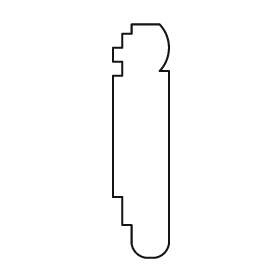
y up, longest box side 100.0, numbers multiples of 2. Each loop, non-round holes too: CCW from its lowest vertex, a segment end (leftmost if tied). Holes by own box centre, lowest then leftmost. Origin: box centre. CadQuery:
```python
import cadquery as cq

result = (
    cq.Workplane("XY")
    .moveTo(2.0, -50.0)
    .lineTo(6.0, -50.0)
    .threePointArc((10.0, -48.0), (12.0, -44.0))
    .lineTo(12.0, 30.0)
    .lineTo(8.0, 30.0)
    .threePointArc((12.0, 40.0), (8.0, 50.0))
    .lineTo(-4.0, 50.0)
    .lineTo(-4.0, 46.0)
    .lineTo(-8.0, 46.0)
    .lineTo(-8.0, 40.0)
    .lineTo(-12.0, 40.0)
    .lineTo(-12.0, 34.0)
    .lineTo(-8.0, 34.0)
    .lineTo(-8.0, 28.0)
    .lineTo(-12.0, 28.0)
    .lineTo(-12.0, -24.0)
    .lineTo(-8.0, -24.0)
    .lineTo(-8.0, -36.0)
    .lineTo(-4.0, -36.0)
    .lineTo(-4.0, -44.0)
    .threePointArc((-2.0, -48.0), (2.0, -50.0))
    .close()
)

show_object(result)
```